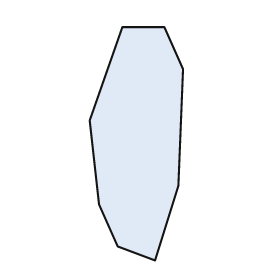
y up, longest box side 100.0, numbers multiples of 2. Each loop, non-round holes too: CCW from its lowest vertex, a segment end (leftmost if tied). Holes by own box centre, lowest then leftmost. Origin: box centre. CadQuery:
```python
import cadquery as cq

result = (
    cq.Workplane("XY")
    .moveTo(8.0, -50.0)
    .lineTo(18.0, -18.0)
    .lineTo(20.0, 32.0)
    .lineTo(12.0, 50.0)
    .lineTo(-6.0, 50.0)
    .lineTo(-20.0, 10.0)
    .lineTo(-16.0, -26.0)
    .lineTo(-8.0, -44.0)
    .close()
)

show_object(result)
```